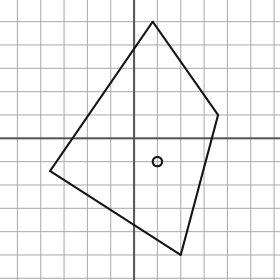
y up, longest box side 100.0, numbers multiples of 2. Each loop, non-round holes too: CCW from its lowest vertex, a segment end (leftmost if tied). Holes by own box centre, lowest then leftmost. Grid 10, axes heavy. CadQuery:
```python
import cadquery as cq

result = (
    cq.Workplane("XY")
    .moveTo(20.0, -50.0)
    .lineTo(36.0, 10.0)
    .lineTo(8.0, 50.0)
    .lineTo(-36.0, -14.0)
    .close()
    .moveTo(10.0, -10.0)
    .circle(2.0)
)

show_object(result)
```